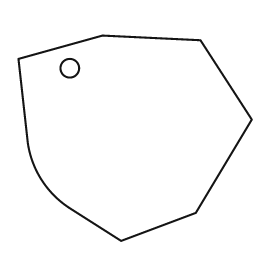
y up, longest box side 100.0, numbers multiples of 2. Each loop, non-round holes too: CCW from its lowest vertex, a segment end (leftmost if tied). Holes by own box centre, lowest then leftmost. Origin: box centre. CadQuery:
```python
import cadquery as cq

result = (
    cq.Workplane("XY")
    .moveTo(-6.0, -44.0)
    .lineTo(26.0, -32.0)
    .lineTo(50.0, 8.0)
    .lineTo(28.0, 42.0)
    .lineTo(-14.0, 44.0)
    .lineTo(-50.0, 34.0)
    .lineTo(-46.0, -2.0)
    .threePointArc((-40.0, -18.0), (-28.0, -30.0))
    .close()
    .moveTo(-28.0, 30.0)
    .circle(4.0)
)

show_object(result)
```